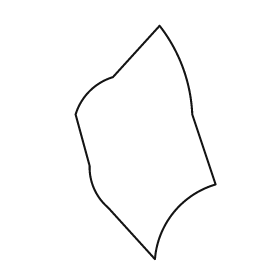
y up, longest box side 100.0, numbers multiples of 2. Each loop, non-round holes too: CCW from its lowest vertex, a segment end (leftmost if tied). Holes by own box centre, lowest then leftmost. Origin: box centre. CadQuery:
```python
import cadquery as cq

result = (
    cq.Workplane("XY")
    .moveTo(4.0, -50.0)
    .threePointArc((12.0, -30.0), (30.0, -18.0))
    .lineTo(20.0, 12.0)
    .threePointArc((16.0, 32.0), (6.0, 50.0))
    .lineTo(-14.0, 28.0)
    .threePointArc((-24.0, 22.0), (-30.0, 12.0))
    .lineTo(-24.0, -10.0)
    .threePointArc((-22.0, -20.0), (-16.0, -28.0))
    .close()
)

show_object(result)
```